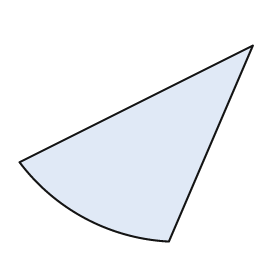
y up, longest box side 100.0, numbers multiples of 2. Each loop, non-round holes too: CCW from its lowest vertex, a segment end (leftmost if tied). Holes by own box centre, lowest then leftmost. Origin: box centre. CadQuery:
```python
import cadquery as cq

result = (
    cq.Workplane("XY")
    .moveTo(14.0, -42.0)
    .lineTo(50.0, 42.0)
    .lineTo(-50.0, -8.0)
    .threePointArc((-22.0, -32.0), (14.0, -42.0))
    .close()
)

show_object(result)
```